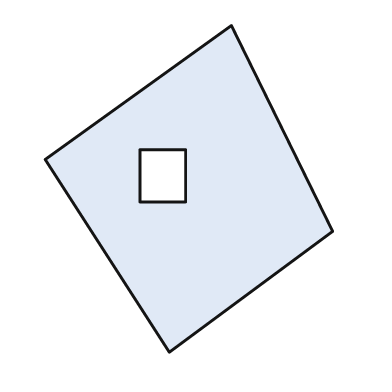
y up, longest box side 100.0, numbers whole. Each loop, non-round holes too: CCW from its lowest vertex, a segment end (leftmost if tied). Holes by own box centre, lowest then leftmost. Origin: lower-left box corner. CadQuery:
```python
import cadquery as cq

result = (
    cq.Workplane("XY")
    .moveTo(38.0, 0.0)
    .lineTo(88.0, 37.0)
    .lineTo(57.0, 100.0)
    .lineTo(0.0, 59.0)
    .close()
    .moveTo(29.0, 46.0)
    .lineTo(43.0, 46.0)
    .lineTo(43.0, 62.0)
    .lineTo(29.0, 62.0)
    .close()
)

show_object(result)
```